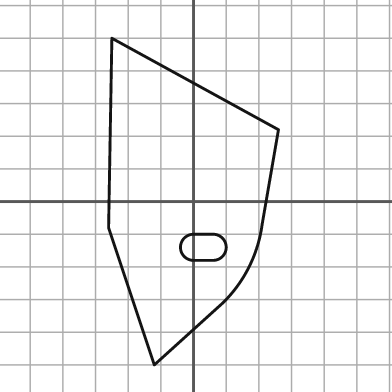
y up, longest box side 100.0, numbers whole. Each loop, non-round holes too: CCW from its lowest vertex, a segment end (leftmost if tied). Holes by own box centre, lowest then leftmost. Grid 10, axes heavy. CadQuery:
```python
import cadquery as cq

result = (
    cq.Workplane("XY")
    .moveTo(-12.0, -50.0)
    .lineTo(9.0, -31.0)
    .threePointArc((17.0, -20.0), (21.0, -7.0))
    .lineTo(26.0, 22.0)
    .lineTo(-25.0, 50.0)
    .lineTo(-26.0, -8.0)
    .close()
    .moveTo(0.0, -18.0)
    .lineTo(6.0, -18.0)
    .threePointArc((10.0, -14.0), (6.0, -10.0))
    .lineTo(0.0, -10.0)
    .threePointArc((-4.0, -14.0), (0.0, -18.0))
    .close()
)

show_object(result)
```